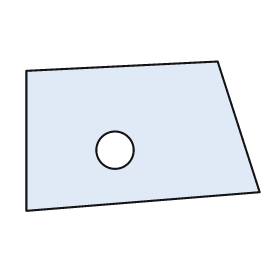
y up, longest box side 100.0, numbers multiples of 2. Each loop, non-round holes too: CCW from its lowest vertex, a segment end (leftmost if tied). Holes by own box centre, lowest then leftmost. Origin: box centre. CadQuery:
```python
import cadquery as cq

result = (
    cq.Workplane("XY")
    .moveTo(-50.0, -32.0)
    .lineTo(50.0, -24.0)
    .lineTo(32.0, 32.0)
    .lineTo(-50.0, 28.0)
    .close()
    .moveTo(-12.0, -6.0)
    .circle(8.0)
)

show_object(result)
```